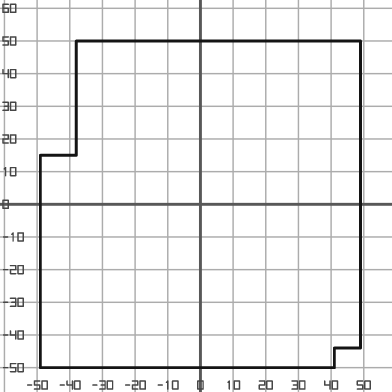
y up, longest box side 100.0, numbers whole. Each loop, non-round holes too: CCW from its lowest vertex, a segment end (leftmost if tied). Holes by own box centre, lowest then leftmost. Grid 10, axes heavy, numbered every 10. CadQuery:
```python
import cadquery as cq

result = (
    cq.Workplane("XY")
    .moveTo(-49.0, -50.0)
    .lineTo(41.0, -50.0)
    .lineTo(41.0, -44.0)
    .lineTo(49.0, -44.0)
    .lineTo(49.0, 50.0)
    .lineTo(-38.0, 50.0)
    .lineTo(-38.0, 15.0)
    .lineTo(-49.0, 15.0)
    .close()
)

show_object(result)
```